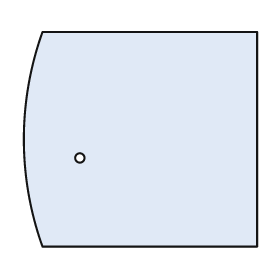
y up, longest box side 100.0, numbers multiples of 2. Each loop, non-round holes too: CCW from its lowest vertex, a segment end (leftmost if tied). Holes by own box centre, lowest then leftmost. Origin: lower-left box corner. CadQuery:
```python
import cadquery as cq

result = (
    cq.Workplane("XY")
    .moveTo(8.0, 0.0)
    .lineTo(100.0, 0.0)
    .lineTo(100.0, 92.0)
    .lineTo(8.0, 92.0)
    .threePointArc((0.0, 46.0), (8.0, 0.0))
    .close()
    .moveTo(24.0, 38.0)
    .circle(2.0)
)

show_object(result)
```